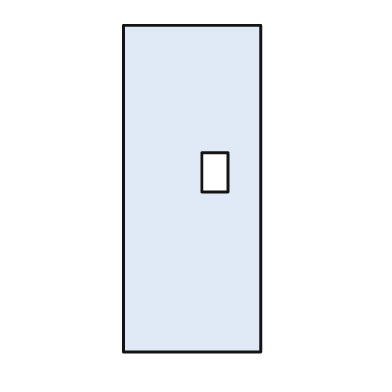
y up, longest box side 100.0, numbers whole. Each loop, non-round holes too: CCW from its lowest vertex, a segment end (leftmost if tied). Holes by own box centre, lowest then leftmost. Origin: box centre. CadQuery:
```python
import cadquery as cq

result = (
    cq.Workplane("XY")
    .moveTo(-21.0, -50.0)
    .lineTo(21.0, -50.0)
    .lineTo(21.0, 50.0)
    .lineTo(-21.0, 50.0)
    .close()
    .moveTo(3.0, -1.0)
    .lineTo(11.0, -1.0)
    .lineTo(11.0, 11.0)
    .lineTo(3.0, 11.0)
    .close()
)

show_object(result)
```